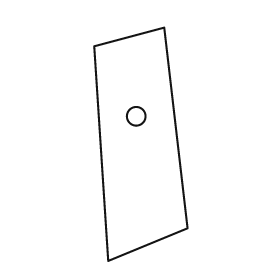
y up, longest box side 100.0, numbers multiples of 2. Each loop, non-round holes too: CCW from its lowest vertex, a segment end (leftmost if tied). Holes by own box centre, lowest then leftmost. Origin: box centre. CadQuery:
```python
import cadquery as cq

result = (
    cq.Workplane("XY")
    .moveTo(-14.0, -50.0)
    .lineTo(20.0, -36.0)
    .lineTo(10.0, 50.0)
    .lineTo(-20.0, 42.0)
    .close()
    .moveTo(-2.0, 12.0)
    .circle(4.0)
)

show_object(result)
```